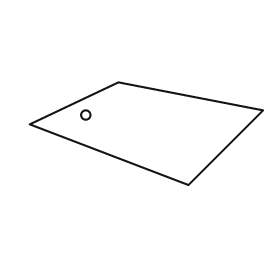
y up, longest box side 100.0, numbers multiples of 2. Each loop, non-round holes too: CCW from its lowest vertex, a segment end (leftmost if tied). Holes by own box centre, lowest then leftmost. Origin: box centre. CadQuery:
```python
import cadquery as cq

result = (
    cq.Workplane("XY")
    .moveTo(18.0, -22.0)
    .lineTo(50.0, 10.0)
    .lineTo(-12.0, 22.0)
    .lineTo(-50.0, 4.0)
    .close()
    .moveTo(-26.0, 8.0)
    .circle(2.0)
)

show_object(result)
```